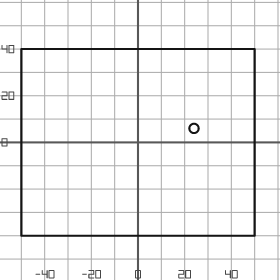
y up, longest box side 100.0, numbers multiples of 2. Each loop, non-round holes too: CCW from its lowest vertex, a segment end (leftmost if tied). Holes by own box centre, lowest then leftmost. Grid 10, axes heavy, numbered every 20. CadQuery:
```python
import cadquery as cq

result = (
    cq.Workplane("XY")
    .moveTo(-50.0, -40.0)
    .lineTo(50.0, -40.0)
    .lineTo(50.0, 40.0)
    .lineTo(-50.0, 40.0)
    .close()
    .moveTo(24.0, 6.0)
    .circle(2.0)
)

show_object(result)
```